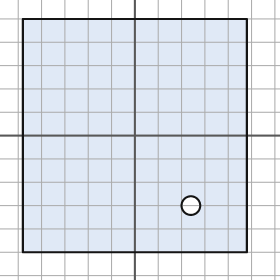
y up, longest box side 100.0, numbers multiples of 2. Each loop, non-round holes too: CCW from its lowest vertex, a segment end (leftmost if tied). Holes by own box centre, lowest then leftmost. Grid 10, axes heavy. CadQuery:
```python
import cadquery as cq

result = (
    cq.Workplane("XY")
    .moveTo(-48.0, -50.0)
    .lineTo(48.0, -50.0)
    .lineTo(48.0, 50.0)
    .lineTo(-48.0, 50.0)
    .close()
    .moveTo(24.0, -30.0)
    .circle(4.0)
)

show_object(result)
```